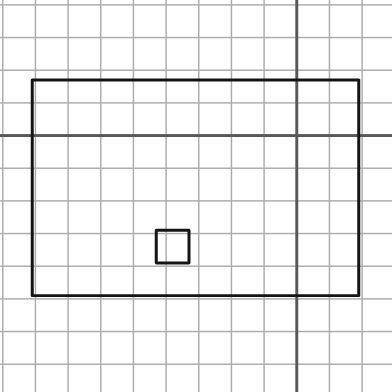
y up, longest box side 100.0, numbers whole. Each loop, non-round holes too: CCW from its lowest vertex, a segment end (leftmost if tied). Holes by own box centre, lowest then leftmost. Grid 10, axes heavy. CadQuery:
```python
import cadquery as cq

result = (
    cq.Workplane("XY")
    .moveTo(-81.0, -49.0)
    .lineTo(19.0, -49.0)
    .lineTo(19.0, 17.0)
    .lineTo(-81.0, 17.0)
    .close()
    .moveTo(-43.0, -39.0)
    .lineTo(-33.0, -39.0)
    .lineTo(-33.0, -29.0)
    .lineTo(-43.0, -29.0)
    .close()
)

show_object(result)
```